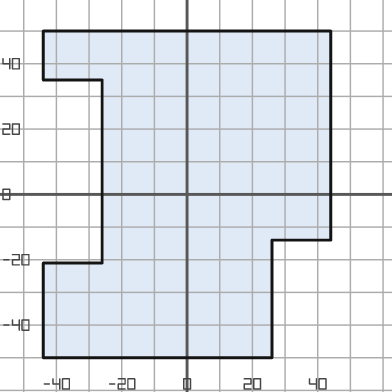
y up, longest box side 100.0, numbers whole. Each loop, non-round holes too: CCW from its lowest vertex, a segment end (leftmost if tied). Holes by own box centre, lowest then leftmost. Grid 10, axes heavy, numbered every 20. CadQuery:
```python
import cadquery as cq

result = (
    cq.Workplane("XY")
    .moveTo(-44.0, -50.0)
    .lineTo(26.0, -50.0)
    .lineTo(26.0, -14.0)
    .lineTo(44.0, -14.0)
    .lineTo(44.0, 50.0)
    .lineTo(-44.0, 50.0)
    .lineTo(-44.0, 35.0)
    .lineTo(-26.0, 35.0)
    .lineTo(-26.0, -21.0)
    .lineTo(-44.0, -21.0)
    .close()
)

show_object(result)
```